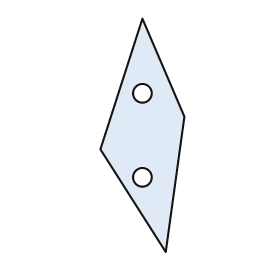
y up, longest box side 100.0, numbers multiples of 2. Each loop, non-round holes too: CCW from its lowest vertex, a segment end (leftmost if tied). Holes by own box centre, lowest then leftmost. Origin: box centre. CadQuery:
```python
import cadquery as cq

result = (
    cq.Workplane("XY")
    .moveTo(10.0, -50.0)
    .lineTo(18.0, 8.0)
    .lineTo(0.0, 50.0)
    .lineTo(-18.0, -6.0)
    .close()
    .moveTo(0.0, -18.0)
    .circle(4.0)
    .moveTo(0.0, 18.0)
    .circle(4.0)
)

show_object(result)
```